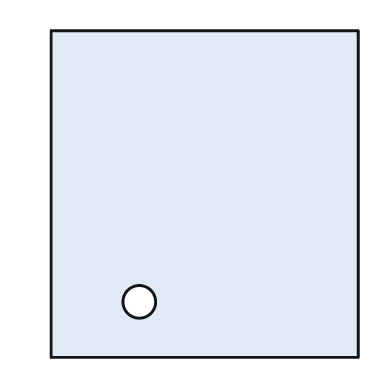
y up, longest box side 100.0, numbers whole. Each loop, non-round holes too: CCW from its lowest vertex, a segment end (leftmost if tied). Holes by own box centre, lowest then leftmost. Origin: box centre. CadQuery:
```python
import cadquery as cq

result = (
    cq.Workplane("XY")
    .moveTo(-47.0, -50.0)
    .lineTo(47.0, -50.0)
    .lineTo(47.0, 50.0)
    .lineTo(-47.0, 50.0)
    .close()
    .moveTo(-20.0, -33.0)
    .circle(5.0)
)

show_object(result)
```